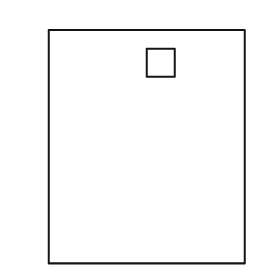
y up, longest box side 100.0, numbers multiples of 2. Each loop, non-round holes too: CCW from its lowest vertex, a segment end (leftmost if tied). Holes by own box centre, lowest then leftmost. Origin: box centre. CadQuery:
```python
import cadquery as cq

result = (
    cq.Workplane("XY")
    .moveTo(-42.0, -50.0)
    .lineTo(42.0, -50.0)
    .lineTo(42.0, 50.0)
    .lineTo(-42.0, 50.0)
    .close()
    .moveTo(0.0, 30.0)
    .lineTo(12.0, 30.0)
    .lineTo(12.0, 42.0)
    .lineTo(0.0, 42.0)
    .close()
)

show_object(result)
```